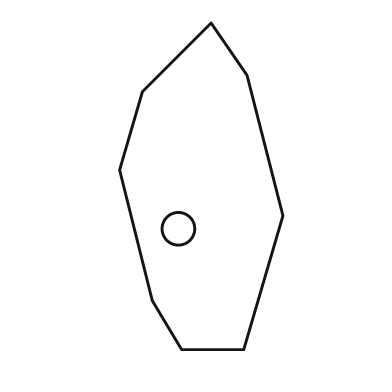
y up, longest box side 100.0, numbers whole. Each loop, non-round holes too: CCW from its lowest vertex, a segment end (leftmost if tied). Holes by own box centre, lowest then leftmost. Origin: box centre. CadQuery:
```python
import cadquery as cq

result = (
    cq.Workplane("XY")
    .moveTo(-6.0, -50.0)
    .lineTo(13.0, -50.0)
    .lineTo(25.0, -9.0)
    .lineTo(14.0, 34.0)
    .lineTo(3.0, 50.0)
    .lineTo(-18.0, 29.0)
    .lineTo(-25.0, 5.0)
    .lineTo(-15.0, -35.0)
    .close()
    .moveTo(-7.0, -13.0)
    .circle(5.0)
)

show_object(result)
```